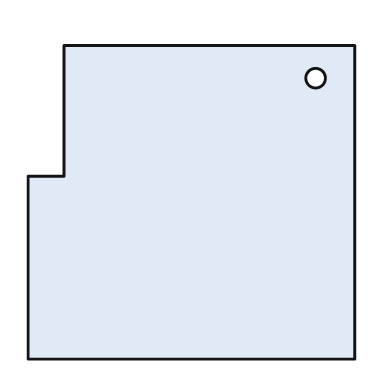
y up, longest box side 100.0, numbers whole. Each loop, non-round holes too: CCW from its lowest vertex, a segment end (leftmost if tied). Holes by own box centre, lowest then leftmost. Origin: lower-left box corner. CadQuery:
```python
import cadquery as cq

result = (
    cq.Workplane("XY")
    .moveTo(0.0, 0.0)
    .lineTo(100.0, 0.0)
    .lineTo(100.0, 96.0)
    .lineTo(11.0, 96.0)
    .lineTo(11.0, 56.0)
    .lineTo(0.0, 56.0)
    .close()
    .moveTo(88.0, 86.0)
    .circle(3.0)
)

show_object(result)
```